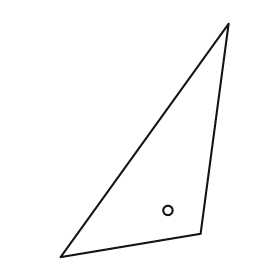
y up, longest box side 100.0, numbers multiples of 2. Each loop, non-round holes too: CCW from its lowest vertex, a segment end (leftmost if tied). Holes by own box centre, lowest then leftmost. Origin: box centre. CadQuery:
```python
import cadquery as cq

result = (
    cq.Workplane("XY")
    .moveTo(-36.0, -50.0)
    .lineTo(24.0, -40.0)
    .lineTo(36.0, 50.0)
    .close()
    .moveTo(10.0, -30.0)
    .circle(2.0)
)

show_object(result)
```